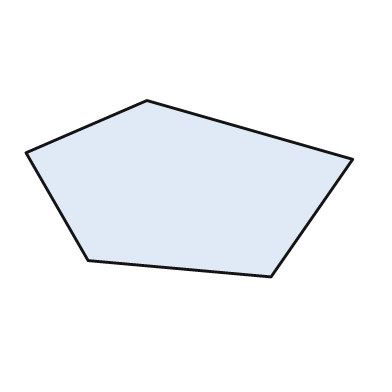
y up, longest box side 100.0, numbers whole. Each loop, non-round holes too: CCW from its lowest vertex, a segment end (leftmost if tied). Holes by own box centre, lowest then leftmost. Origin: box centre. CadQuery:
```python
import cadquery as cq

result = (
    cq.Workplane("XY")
    .moveTo(25.0, -27.0)
    .lineTo(50.0, 9.0)
    .lineTo(-13.0, 27.0)
    .lineTo(-50.0, 11.0)
    .lineTo(-31.0, -22.0)
    .close()
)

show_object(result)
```